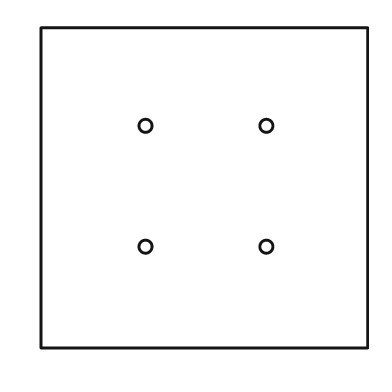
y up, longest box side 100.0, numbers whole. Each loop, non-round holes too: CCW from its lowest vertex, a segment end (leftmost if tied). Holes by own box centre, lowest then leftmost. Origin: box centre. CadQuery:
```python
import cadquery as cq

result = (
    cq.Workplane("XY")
    .moveTo(-50.0, -49.0)
    .lineTo(50.0, -49.0)
    .lineTo(50.0, 49.0)
    .lineTo(-50.0, 49.0)
    .close()
    .moveTo(-18.0, -18.0)
    .circle(2.0)
    .moveTo(19.0, -18.0)
    .circle(2.0)
    .moveTo(-18.0, 19.0)
    .circle(2.0)
    .moveTo(19.0, 19.0)
    .circle(2.0)
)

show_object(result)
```